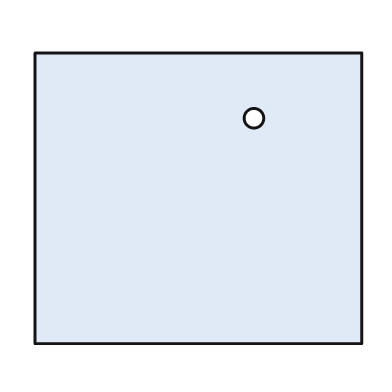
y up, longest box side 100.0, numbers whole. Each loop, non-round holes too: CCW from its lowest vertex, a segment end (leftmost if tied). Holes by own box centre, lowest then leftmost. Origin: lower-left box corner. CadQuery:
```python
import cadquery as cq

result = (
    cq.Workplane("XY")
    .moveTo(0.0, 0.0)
    .lineTo(100.0, 0.0)
    .lineTo(100.0, 89.0)
    .lineTo(0.0, 89.0)
    .close()
    .moveTo(67.0, 69.0)
    .circle(3.0)
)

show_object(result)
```